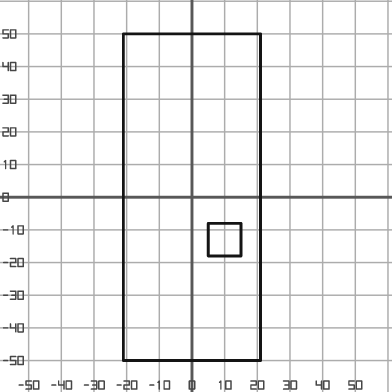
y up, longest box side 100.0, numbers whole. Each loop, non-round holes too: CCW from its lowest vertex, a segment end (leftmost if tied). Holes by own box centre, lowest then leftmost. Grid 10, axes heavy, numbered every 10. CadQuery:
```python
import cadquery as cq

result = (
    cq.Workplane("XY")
    .moveTo(-21.0, -50.0)
    .lineTo(21.0, -50.0)
    .lineTo(21.0, 50.0)
    .lineTo(-21.0, 50.0)
    .close()
    .moveTo(5.0, -18.0)
    .lineTo(15.0, -18.0)
    .lineTo(15.0, -8.0)
    .lineTo(5.0, -8.0)
    .close()
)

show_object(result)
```